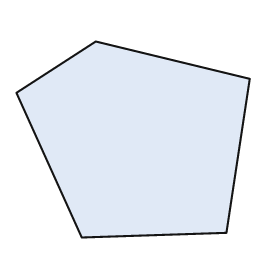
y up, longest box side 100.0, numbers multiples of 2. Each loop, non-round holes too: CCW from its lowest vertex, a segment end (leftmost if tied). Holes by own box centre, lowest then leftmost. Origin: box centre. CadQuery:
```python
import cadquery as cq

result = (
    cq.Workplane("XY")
    .moveTo(-22.0, -42.0)
    .lineTo(40.0, -40.0)
    .lineTo(50.0, 26.0)
    .lineTo(-16.0, 42.0)
    .lineTo(-50.0, 20.0)
    .close()
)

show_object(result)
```